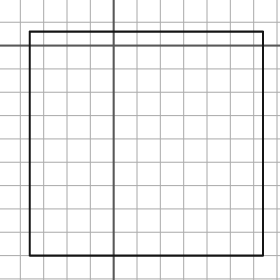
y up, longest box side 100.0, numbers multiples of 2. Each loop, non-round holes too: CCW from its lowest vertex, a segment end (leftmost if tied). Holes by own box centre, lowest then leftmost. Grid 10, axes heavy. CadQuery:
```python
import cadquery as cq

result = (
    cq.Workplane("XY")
    .moveTo(-36.0, -90.0)
    .lineTo(64.0, -90.0)
    .lineTo(64.0, 6.0)
    .lineTo(-36.0, 6.0)
    .close()
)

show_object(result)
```